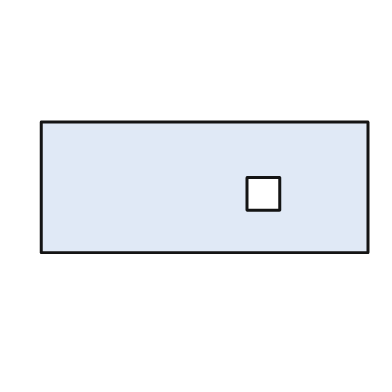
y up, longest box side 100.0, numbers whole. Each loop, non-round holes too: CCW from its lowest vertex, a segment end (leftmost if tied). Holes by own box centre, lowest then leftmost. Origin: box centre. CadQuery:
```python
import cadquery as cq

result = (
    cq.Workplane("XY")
    .moveTo(-50.0, -20.0)
    .lineTo(50.0, -20.0)
    .lineTo(50.0, 20.0)
    .lineTo(-50.0, 20.0)
    .close()
    .moveTo(13.0, -7.0)
    .lineTo(23.0, -7.0)
    .lineTo(23.0, 3.0)
    .lineTo(13.0, 3.0)
    .close()
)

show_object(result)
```